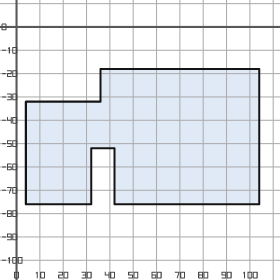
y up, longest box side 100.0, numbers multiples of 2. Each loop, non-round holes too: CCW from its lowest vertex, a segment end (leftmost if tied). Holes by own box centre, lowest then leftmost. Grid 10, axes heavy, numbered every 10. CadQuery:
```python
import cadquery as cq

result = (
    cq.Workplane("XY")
    .moveTo(4.0, -76.0)
    .lineTo(32.0, -76.0)
    .lineTo(32.0, -52.0)
    .lineTo(42.0, -52.0)
    .lineTo(42.0, -76.0)
    .lineTo(104.0, -76.0)
    .lineTo(104.0, -18.0)
    .lineTo(36.0, -18.0)
    .lineTo(36.0, -32.0)
    .lineTo(4.0, -32.0)
    .close()
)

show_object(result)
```